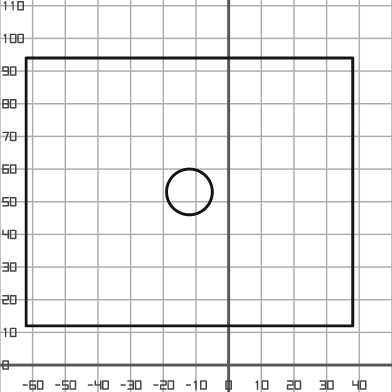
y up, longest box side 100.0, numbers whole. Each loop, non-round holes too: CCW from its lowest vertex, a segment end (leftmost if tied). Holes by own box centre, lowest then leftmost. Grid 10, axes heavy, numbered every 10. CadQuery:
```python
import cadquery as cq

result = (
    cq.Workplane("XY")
    .moveTo(-62.0, 12.0)
    .lineTo(38.0, 12.0)
    .lineTo(38.0, 94.0)
    .lineTo(-62.0, 94.0)
    .close()
    .moveTo(-12.0, 53.0)
    .circle(7.0)
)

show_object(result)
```